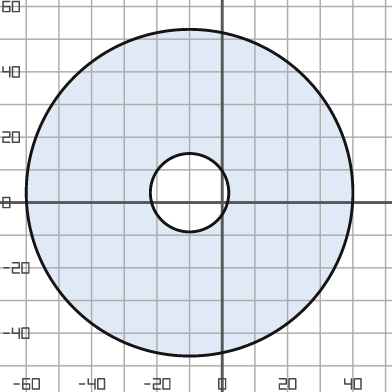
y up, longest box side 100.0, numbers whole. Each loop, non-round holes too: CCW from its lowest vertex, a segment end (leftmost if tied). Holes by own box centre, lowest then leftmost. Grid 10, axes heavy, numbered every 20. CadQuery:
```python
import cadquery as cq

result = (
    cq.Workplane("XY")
    .moveTo(-10.0, 3.0)
    .circle(50.0)
    .moveTo(-10.0, 3.0)
    .circle(12.0)
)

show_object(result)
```